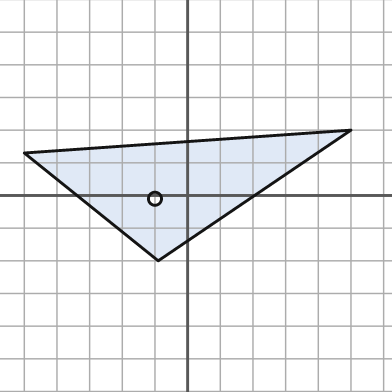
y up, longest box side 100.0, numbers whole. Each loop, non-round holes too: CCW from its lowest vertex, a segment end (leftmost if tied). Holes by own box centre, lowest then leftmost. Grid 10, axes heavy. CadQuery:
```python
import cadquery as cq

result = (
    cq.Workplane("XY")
    .moveTo(-9.0, -20.0)
    .lineTo(50.0, 20.0)
    .lineTo(-50.0, 13.0)
    .close()
    .moveTo(-10.0, -1.0)
    .circle(2.0)
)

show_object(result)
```